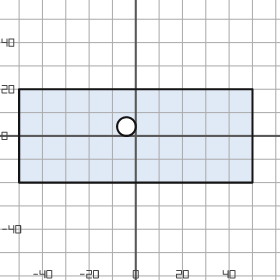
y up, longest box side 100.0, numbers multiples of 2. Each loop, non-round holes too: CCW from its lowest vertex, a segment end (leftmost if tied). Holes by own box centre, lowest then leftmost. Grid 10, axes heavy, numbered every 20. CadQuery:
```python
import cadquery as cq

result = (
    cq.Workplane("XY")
    .moveTo(-50.0, -20.0)
    .lineTo(50.0, -20.0)
    .lineTo(50.0, 20.0)
    .lineTo(-50.0, 20.0)
    .close()
    .moveTo(-4.0, 4.0)
    .circle(4.0)
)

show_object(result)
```